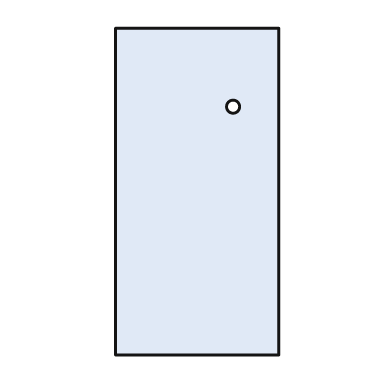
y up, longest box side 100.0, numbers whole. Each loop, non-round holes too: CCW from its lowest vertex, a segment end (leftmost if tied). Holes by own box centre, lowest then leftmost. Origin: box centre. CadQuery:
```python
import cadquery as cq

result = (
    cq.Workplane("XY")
    .moveTo(-25.0, -50.0)
    .lineTo(25.0, -50.0)
    .lineTo(25.0, 50.0)
    .lineTo(-25.0, 50.0)
    .close()
    .moveTo(11.0, 26.0)
    .circle(2.0)
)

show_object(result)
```